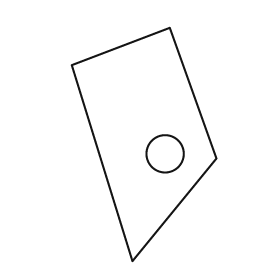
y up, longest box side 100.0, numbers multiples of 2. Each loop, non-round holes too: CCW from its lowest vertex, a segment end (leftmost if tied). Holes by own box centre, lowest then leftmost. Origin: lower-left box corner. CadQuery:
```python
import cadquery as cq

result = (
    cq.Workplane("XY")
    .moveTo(26.0, 0.0)
    .lineTo(62.0, 44.0)
    .lineTo(42.0, 100.0)
    .lineTo(0.0, 84.0)
    .close()
    .moveTo(40.0, 46.0)
    .circle(8.0)
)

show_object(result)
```